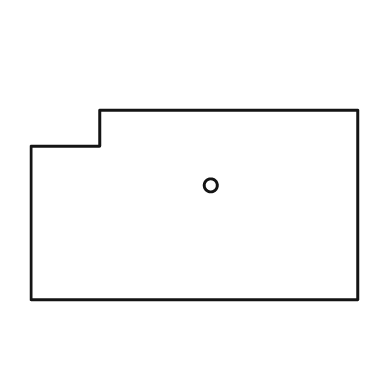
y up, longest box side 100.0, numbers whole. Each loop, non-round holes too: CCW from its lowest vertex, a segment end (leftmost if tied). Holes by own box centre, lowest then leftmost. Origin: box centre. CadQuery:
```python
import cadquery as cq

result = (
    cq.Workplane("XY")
    .moveTo(-50.0, -29.0)
    .lineTo(50.0, -29.0)
    .lineTo(50.0, 29.0)
    .lineTo(-29.0, 29.0)
    .lineTo(-29.0, 18.0)
    .lineTo(-50.0, 18.0)
    .close()
    .moveTo(5.0, 6.0)
    .circle(2.0)
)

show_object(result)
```